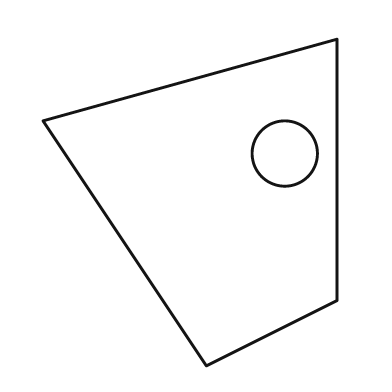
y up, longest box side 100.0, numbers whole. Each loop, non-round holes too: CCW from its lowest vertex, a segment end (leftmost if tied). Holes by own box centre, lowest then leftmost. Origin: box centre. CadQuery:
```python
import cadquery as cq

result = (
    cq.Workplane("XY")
    .moveTo(5.0, -50.0)
    .lineTo(45.0, -30.0)
    .lineTo(45.0, 50.0)
    .lineTo(-45.0, 25.0)
    .close()
    .moveTo(29.0, 15.0)
    .circle(10.0)
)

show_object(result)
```